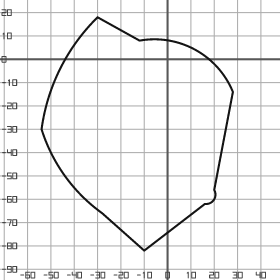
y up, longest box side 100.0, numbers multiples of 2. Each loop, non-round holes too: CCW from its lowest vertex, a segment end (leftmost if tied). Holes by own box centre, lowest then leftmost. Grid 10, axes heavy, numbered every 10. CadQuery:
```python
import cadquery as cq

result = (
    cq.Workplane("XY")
    .moveTo(-10.0, -82.0)
    .lineTo(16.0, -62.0)
    .threePointArc((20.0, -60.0), (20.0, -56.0))
    .lineTo(28.0, -14.0)
    .threePointArc((12.0, 4.0), (-12.0, 8.0))
    .lineTo(-30.0, 18.0)
    .threePointArc((-46.0, -4.0), (-54.0, -30.0))
    .threePointArc((-44.0, -50.0), (-28.0, -66.0))
    .close()
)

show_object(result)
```